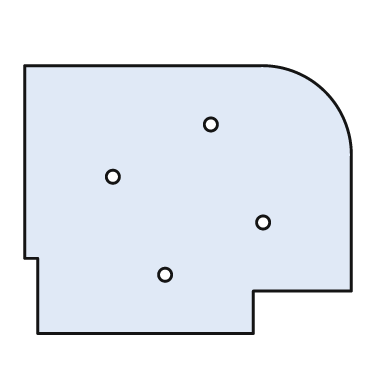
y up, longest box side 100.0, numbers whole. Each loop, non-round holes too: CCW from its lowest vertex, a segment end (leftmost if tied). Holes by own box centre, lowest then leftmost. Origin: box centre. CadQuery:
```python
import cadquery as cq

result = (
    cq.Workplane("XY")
    .moveTo(-46.0, -41.0)
    .lineTo(20.0, -41.0)
    .lineTo(20.0, -28.0)
    .lineTo(50.0, -28.0)
    .lineTo(50.0, 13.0)
    .threePointArc((42.0, 33.0), (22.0, 41.0))
    .lineTo(-50.0, 41.0)
    .lineTo(-50.0, -18.0)
    .lineTo(-46.0, -18.0)
    .close()
    .moveTo(-7.0, -23.0)
    .circle(2.0)
    .moveTo(23.0, -7.0)
    .circle(2.0)
    .moveTo(-23.0, 7.0)
    .circle(2.0)
    .moveTo(7.0, 23.0)
    .circle(2.0)
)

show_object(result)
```